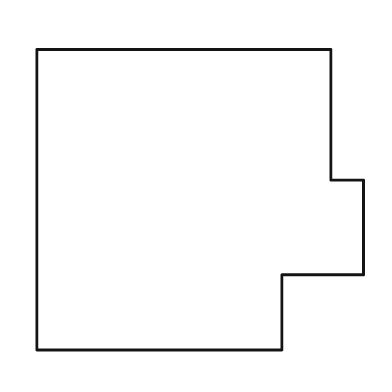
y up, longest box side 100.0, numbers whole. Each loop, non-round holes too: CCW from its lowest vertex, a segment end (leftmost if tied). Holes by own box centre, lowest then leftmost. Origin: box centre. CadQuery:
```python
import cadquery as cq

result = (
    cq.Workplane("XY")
    .moveTo(-50.0, -46.0)
    .lineTo(25.0, -46.0)
    .lineTo(25.0, -23.0)
    .lineTo(50.0, -23.0)
    .lineTo(50.0, 6.0)
    .lineTo(40.0, 6.0)
    .lineTo(40.0, 46.0)
    .lineTo(-50.0, 46.0)
    .close()
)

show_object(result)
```